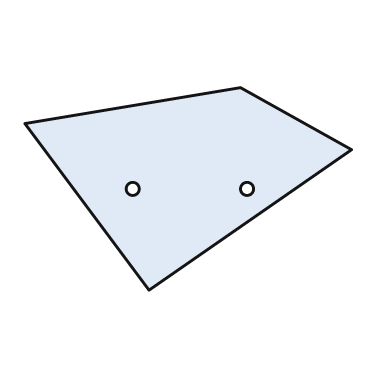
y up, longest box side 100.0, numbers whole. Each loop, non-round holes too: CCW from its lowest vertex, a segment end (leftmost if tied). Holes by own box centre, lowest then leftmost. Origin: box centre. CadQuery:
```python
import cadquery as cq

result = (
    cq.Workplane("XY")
    .moveTo(-12.0, -31.0)
    .lineTo(50.0, 12.0)
    .lineTo(16.0, 31.0)
    .lineTo(-50.0, 20.0)
    .close()
    .moveTo(-17.0, 0.0)
    .circle(2.0)
    .moveTo(18.0, 0.0)
    .circle(2.0)
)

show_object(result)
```